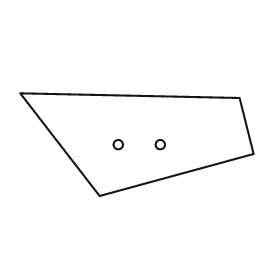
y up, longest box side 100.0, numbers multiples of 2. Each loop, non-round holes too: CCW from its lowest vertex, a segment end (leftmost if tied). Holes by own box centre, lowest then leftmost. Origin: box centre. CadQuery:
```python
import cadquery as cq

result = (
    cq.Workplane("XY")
    .moveTo(-16.0, -22.0)
    .lineTo(50.0, -4.0)
    .lineTo(44.0, 20.0)
    .lineTo(-50.0, 22.0)
    .close()
    .moveTo(-8.0, 0.0)
    .circle(2.0)
    .moveTo(10.0, 0.0)
    .circle(2.0)
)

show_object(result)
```